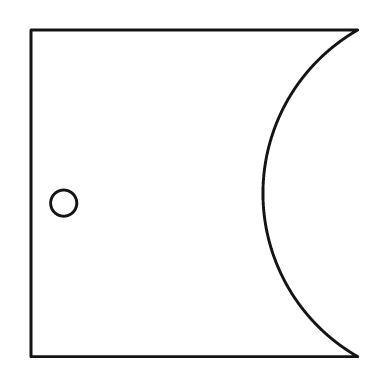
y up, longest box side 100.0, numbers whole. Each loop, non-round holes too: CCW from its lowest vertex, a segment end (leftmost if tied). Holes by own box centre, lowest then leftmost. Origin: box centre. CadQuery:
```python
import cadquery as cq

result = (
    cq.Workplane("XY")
    .moveTo(-50.0, -50.0)
    .lineTo(50.0, -50.0)
    .threePointArc((21.0, 0.0), (50.0, 50.0))
    .lineTo(-50.0, 50.0)
    .close()
    .moveTo(-40.0, -3.0)
    .circle(4.0)
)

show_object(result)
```